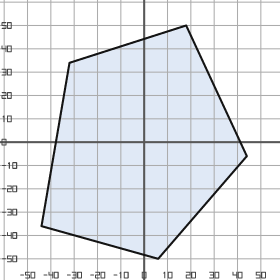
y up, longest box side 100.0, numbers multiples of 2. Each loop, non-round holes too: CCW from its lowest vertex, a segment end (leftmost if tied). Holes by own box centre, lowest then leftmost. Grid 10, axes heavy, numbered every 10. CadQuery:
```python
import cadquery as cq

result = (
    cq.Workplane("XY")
    .moveTo(6.0, -50.0)
    .lineTo(44.0, -6.0)
    .lineTo(18.0, 50.0)
    .lineTo(-32.0, 34.0)
    .lineTo(-44.0, -36.0)
    .close()
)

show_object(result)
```